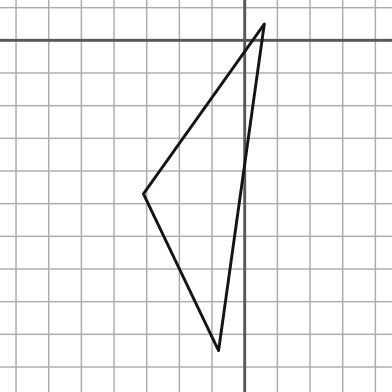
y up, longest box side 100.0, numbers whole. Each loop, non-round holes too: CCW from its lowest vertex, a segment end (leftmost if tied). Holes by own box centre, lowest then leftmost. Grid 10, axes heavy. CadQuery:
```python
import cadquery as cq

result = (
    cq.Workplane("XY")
    .moveTo(-8.0, -95.0)
    .lineTo(6.0, 5.0)
    .lineTo(-31.0, -47.0)
    .close()
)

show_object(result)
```